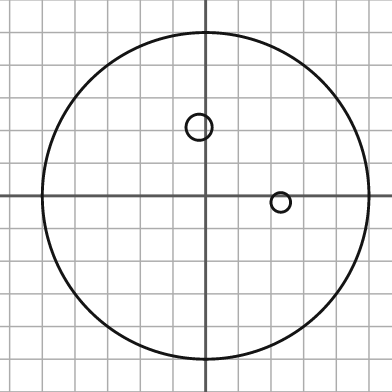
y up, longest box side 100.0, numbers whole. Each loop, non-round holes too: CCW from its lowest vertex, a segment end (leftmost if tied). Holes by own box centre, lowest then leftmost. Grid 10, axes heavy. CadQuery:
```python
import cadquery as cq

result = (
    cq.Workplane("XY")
    .moveTo(0.0, 0.0)
    .circle(50.0)
    .moveTo(23.0, -2.0)
    .circle(3.0)
    .moveTo(-2.0, 21.0)
    .circle(4.0)
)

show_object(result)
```